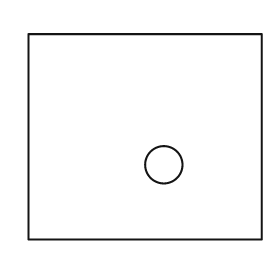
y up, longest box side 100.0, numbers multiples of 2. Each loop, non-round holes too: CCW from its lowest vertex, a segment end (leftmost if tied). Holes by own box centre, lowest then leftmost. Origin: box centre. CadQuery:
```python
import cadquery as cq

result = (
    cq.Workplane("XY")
    .moveTo(-50.0, -44.0)
    .lineTo(50.0, -44.0)
    .lineTo(50.0, 44.0)
    .lineTo(-50.0, 44.0)
    .close()
    .moveTo(8.0, -12.0)
    .circle(8.0)
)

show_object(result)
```